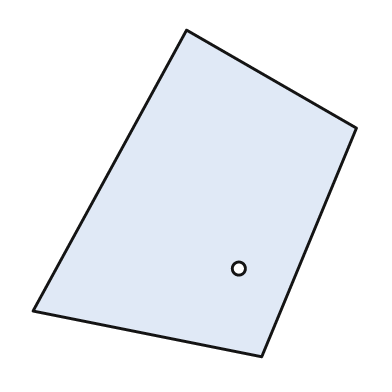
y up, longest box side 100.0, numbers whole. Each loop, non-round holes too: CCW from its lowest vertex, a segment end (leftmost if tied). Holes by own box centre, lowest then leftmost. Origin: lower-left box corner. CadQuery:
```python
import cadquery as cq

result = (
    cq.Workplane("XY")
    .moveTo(70.0, 0.0)
    .lineTo(99.0, 70.0)
    .lineTo(47.0, 100.0)
    .lineTo(0.0, 14.0)
    .close()
    .moveTo(63.0, 27.0)
    .circle(2.0)
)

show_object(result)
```